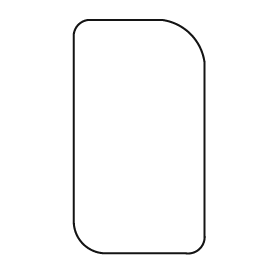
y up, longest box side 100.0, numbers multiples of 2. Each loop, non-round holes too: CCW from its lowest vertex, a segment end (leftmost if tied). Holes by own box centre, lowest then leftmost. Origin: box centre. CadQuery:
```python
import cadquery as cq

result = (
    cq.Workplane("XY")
    .moveTo(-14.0, -50.0)
    .lineTo(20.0, -50.0)
    .threePointArc((26.0, -48.0), (28.0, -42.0))
    .lineTo(28.0, 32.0)
    .threePointArc((22.0, 44.0), (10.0, 50.0))
    .lineTo(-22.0, 50.0)
    .threePointArc((-26.0, 48.0), (-28.0, 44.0))
    .lineTo(-28.0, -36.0)
    .threePointArc((-24.0, -46.0), (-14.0, -50.0))
    .close()
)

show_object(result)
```